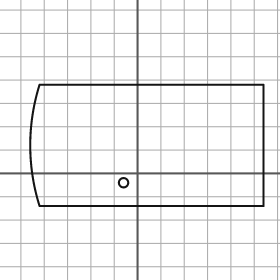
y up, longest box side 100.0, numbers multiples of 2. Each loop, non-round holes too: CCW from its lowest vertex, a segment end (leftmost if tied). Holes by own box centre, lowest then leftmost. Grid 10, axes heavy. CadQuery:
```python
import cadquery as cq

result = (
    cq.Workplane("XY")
    .moveTo(-42.0, -14.0)
    .lineTo(54.0, -14.0)
    .lineTo(54.0, 38.0)
    .lineTo(-42.0, 38.0)
    .threePointArc((-46.0, 12.0), (-42.0, -14.0))
    .close()
    .moveTo(-6.0, -4.0)
    .circle(2.0)
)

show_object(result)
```